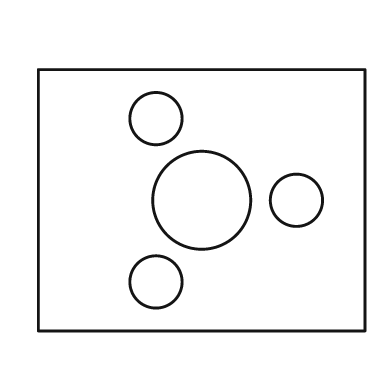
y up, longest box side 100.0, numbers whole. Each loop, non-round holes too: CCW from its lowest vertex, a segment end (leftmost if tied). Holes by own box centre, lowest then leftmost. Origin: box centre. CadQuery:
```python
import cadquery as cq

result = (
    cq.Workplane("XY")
    .moveTo(-50.0, -40.0)
    .lineTo(50.0, -40.0)
    .lineTo(50.0, 40.0)
    .lineTo(-50.0, 40.0)
    .close()
    .moveTo(-14.0, -25.0)
    .circle(8.0)
    .moveTo(0.0, 0.0)
    .circle(15.0)
    .moveTo(29.0, 0.0)
    .circle(8.0)
    .moveTo(-14.0, 25.0)
    .circle(8.0)
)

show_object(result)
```